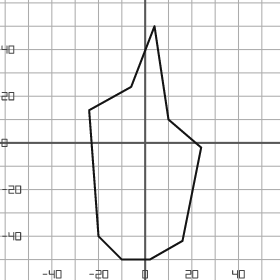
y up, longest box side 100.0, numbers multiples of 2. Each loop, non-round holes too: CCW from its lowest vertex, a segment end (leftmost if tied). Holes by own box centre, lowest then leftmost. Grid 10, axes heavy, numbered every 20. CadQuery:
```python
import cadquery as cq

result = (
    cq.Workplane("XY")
    .moveTo(-10.0, -50.0)
    .lineTo(2.0, -50.0)
    .lineTo(16.0, -42.0)
    .lineTo(24.0, -2.0)
    .lineTo(10.0, 10.0)
    .lineTo(4.0, 50.0)
    .lineTo(-6.0, 24.0)
    .lineTo(-24.0, 14.0)
    .lineTo(-20.0, -40.0)
    .close()
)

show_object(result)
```